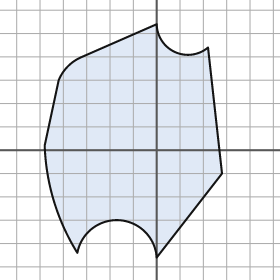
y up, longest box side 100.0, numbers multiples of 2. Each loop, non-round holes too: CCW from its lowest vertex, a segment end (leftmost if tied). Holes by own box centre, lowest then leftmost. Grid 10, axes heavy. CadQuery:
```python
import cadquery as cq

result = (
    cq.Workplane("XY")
    .moveTo(0.0, -46.0)
    .lineTo(28.0, -10.0)
    .lineTo(22.0, 44.0)
    .threePointArc((8.0, 42.0), (0.0, 54.0))
    .lineTo(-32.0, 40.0)
    .threePointArc((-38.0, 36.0), (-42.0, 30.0))
    .lineTo(-48.0, 2.0)
    .threePointArc((-44.0, -22.0), (-34.0, -44.0))
    .threePointArc((-16.0, -30.0), (0.0, -46.0))
    .close()
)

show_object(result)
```